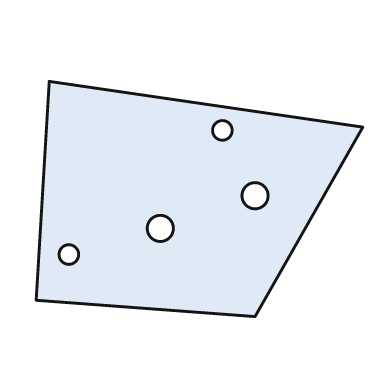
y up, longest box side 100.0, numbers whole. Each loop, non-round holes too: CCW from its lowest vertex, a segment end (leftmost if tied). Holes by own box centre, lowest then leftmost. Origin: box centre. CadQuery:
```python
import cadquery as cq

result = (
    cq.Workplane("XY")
    .moveTo(17.0, -36.0)
    .lineTo(50.0, 22.0)
    .lineTo(-46.0, 36.0)
    .lineTo(-50.0, -31.0)
    .close()
    .moveTo(-40.0, -17.0)
    .circle(3.0)
    .moveTo(-12.0, -9.0)
    .circle(4.0)
    .moveTo(17.0, 1.0)
    .circle(4.0)
    .moveTo(7.0, 21.0)
    .circle(3.0)
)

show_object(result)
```